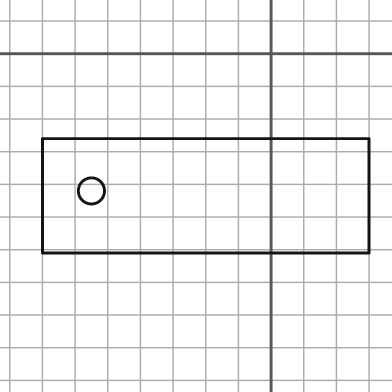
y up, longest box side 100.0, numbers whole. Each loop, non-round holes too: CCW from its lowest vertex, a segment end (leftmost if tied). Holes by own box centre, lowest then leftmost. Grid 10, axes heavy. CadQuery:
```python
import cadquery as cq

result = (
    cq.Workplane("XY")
    .moveTo(-70.0, -61.0)
    .lineTo(30.0, -61.0)
    .lineTo(30.0, -26.0)
    .lineTo(-70.0, -26.0)
    .close()
    .moveTo(-55.0, -42.0)
    .circle(4.0)
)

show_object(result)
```